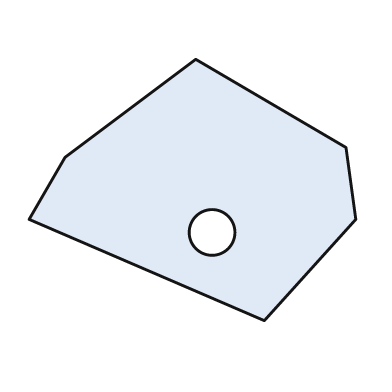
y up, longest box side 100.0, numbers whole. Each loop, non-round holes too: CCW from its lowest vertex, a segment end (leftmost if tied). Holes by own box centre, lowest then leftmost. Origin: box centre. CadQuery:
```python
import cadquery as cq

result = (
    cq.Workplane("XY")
    .moveTo(22.0, -40.0)
    .lineTo(50.0, -9.0)
    .lineTo(47.0, 13.0)
    .lineTo(1.0, 40.0)
    .lineTo(-39.0, 10.0)
    .lineTo(-50.0, -9.0)
    .close()
    .moveTo(6.0, -13.0)
    .circle(7.0)
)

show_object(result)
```